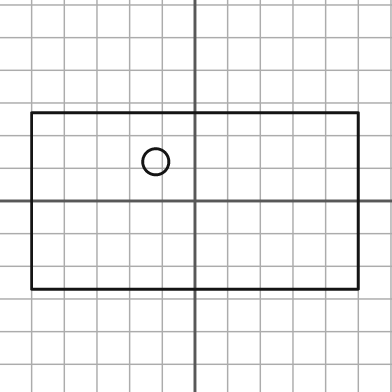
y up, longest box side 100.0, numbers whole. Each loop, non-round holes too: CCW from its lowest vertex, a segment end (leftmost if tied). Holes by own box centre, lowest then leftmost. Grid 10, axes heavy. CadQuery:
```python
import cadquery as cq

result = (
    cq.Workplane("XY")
    .moveTo(-50.0, -27.0)
    .lineTo(50.0, -27.0)
    .lineTo(50.0, 27.0)
    .lineTo(-50.0, 27.0)
    .close()
    .moveTo(-12.0, 12.0)
    .circle(4.0)
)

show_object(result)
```